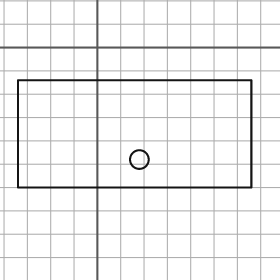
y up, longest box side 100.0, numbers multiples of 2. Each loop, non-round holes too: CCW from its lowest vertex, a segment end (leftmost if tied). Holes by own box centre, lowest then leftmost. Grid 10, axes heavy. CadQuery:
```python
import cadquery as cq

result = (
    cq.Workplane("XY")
    .moveTo(-34.0, -60.0)
    .lineTo(66.0, -60.0)
    .lineTo(66.0, -14.0)
    .lineTo(-34.0, -14.0)
    .close()
    .moveTo(18.0, -48.0)
    .circle(4.0)
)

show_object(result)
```